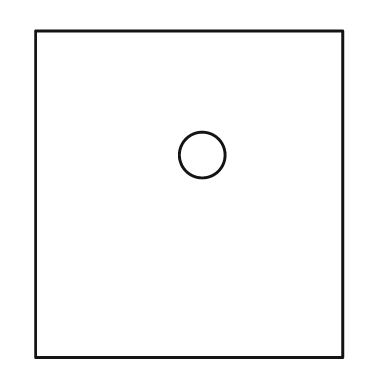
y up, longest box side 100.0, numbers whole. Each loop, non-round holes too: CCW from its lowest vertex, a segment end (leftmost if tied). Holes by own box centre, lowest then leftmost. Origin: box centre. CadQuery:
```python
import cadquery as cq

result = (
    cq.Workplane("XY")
    .moveTo(-47.0, -50.0)
    .lineTo(47.0, -50.0)
    .lineTo(47.0, 50.0)
    .lineTo(-47.0, 50.0)
    .close()
    .moveTo(4.0, 12.0)
    .circle(7.0)
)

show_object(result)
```